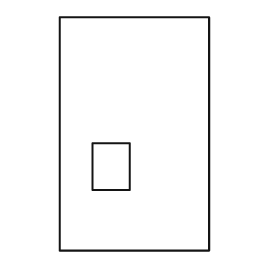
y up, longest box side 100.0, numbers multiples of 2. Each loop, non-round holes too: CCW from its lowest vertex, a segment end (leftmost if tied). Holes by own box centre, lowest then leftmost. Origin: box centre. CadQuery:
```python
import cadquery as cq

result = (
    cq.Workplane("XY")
    .moveTo(-32.0, -50.0)
    .lineTo(32.0, -50.0)
    .lineTo(32.0, 50.0)
    .lineTo(-32.0, 50.0)
    .close()
    .moveTo(-18.0, -24.0)
    .lineTo(-2.0, -24.0)
    .lineTo(-2.0, -4.0)
    .lineTo(-18.0, -4.0)
    .close()
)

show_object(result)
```